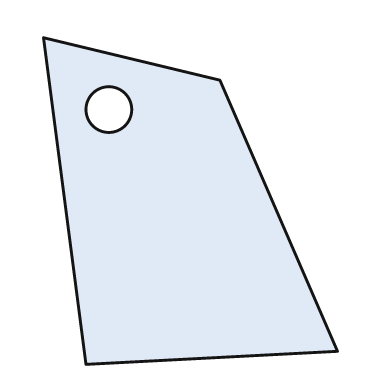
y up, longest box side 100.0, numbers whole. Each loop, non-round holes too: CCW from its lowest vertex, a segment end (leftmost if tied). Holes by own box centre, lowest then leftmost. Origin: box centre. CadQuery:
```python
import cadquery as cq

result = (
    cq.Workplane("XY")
    .moveTo(-32.0, -50.0)
    .lineTo(45.0, -46.0)
    .lineTo(9.0, 37.0)
    .lineTo(-45.0, 50.0)
    .close()
    .moveTo(-25.0, 28.0)
    .circle(7.0)
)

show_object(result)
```